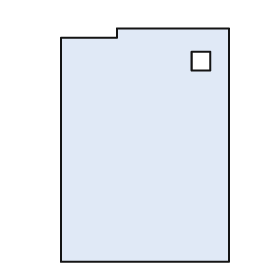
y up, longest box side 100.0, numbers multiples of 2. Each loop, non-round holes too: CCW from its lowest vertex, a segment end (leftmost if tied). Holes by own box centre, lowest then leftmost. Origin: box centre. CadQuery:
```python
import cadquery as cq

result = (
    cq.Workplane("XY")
    .moveTo(-36.0, -50.0)
    .lineTo(36.0, -50.0)
    .lineTo(36.0, 50.0)
    .lineTo(-12.0, 50.0)
    .lineTo(-12.0, 46.0)
    .lineTo(-36.0, 46.0)
    .close()
    .moveTo(20.0, 32.0)
    .lineTo(28.0, 32.0)
    .lineTo(28.0, 40.0)
    .lineTo(20.0, 40.0)
    .close()
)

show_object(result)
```